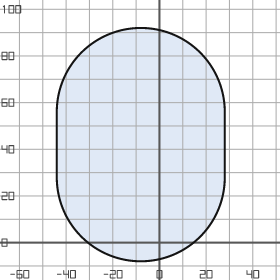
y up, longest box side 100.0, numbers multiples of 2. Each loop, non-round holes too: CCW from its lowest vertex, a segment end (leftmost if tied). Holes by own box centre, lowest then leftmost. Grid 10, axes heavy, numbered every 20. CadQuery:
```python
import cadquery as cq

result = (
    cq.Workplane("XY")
    .moveTo(-44.0, 28.0)
    .threePointArc((-8.0, -8.0), (28.0, 28.0))
    .lineTo(28.0, 56.0)
    .threePointArc((-8.0, 92.0), (-44.0, 56.0))
    .close()
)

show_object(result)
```